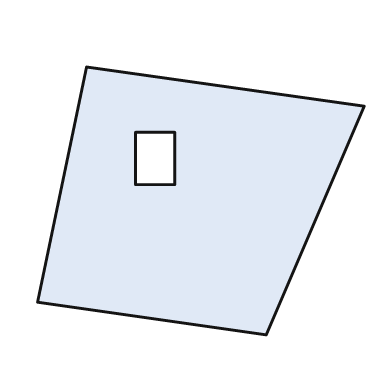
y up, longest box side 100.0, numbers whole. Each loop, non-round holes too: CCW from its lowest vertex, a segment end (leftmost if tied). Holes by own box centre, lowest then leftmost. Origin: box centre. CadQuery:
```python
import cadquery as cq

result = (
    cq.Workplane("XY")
    .moveTo(20.0, -41.0)
    .lineTo(50.0, 29.0)
    .lineTo(-35.0, 41.0)
    .lineTo(-50.0, -31.0)
    .close()
    .moveTo(-20.0, 5.0)
    .lineTo(-8.0, 5.0)
    .lineTo(-8.0, 21.0)
    .lineTo(-20.0, 21.0)
    .close()
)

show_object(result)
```